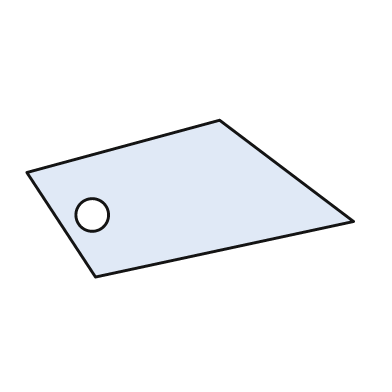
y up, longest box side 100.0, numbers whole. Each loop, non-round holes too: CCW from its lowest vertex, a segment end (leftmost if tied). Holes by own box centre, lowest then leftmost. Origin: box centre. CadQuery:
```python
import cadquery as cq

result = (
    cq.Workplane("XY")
    .moveTo(-29.0, -24.0)
    .lineTo(50.0, -7.0)
    .lineTo(9.0, 24.0)
    .lineTo(-50.0, 8.0)
    .close()
    .moveTo(-30.0, -5.0)
    .circle(5.0)
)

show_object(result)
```